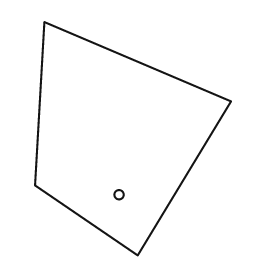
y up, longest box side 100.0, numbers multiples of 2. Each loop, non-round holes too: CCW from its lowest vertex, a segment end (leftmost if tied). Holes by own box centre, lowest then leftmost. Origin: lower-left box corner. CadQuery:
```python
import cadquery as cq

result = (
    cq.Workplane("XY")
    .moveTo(44.0, 0.0)
    .lineTo(84.0, 66.0)
    .lineTo(4.0, 100.0)
    .lineTo(0.0, 30.0)
    .close()
    .moveTo(36.0, 26.0)
    .circle(2.0)
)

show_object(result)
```